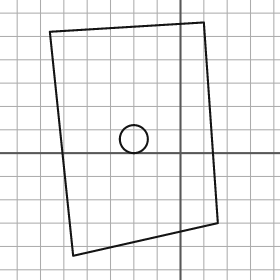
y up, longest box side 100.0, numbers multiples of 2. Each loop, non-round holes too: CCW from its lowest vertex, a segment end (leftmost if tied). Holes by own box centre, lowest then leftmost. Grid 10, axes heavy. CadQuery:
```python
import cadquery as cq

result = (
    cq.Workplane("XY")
    .moveTo(-46.0, -44.0)
    .lineTo(16.0, -30.0)
    .lineTo(10.0, 56.0)
    .lineTo(-56.0, 52.0)
    .close()
    .moveTo(-20.0, 6.0)
    .circle(6.0)
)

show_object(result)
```